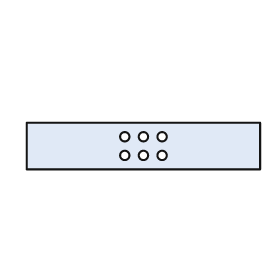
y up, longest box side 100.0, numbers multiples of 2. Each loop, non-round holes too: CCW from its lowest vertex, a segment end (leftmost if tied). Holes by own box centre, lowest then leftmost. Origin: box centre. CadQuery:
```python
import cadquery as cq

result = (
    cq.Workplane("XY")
    .moveTo(-50.0, -10.0)
    .lineTo(50.0, -10.0)
    .lineTo(50.0, 10.0)
    .lineTo(-50.0, 10.0)
    .close()
    .moveTo(-8.0, -4.0)
    .circle(2.0)
    .moveTo(0.0, -4.0)
    .circle(2.0)
    .moveTo(8.0, -4.0)
    .circle(2.0)
    .moveTo(-8.0, 4.0)
    .circle(2.0)
    .moveTo(0.0, 4.0)
    .circle(2.0)
    .moveTo(8.0, 4.0)
    .circle(2.0)
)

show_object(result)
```